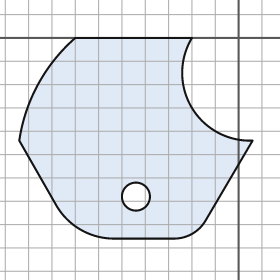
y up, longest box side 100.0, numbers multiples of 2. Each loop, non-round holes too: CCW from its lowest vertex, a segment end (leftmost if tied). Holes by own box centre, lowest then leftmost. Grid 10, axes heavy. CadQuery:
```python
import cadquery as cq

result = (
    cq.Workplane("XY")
    .moveTo(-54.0, -86.0)
    .lineTo(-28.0, -86.0)
    .threePointArc((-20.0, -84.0), (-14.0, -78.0))
    .lineTo(6.0, -44.0)
    .threePointArc((-20.0, -30.0), (-20.0, 0.0))
    .lineTo(-70.0, 0.0)
    .threePointArc((-86.0, -20.0), (-94.0, -44.0))
    .lineTo(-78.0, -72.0)
    .threePointArc((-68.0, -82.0), (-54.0, -86.0))
    .close()
    .moveTo(-44.0, -68.0)
    .circle(6.0)
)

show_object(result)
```